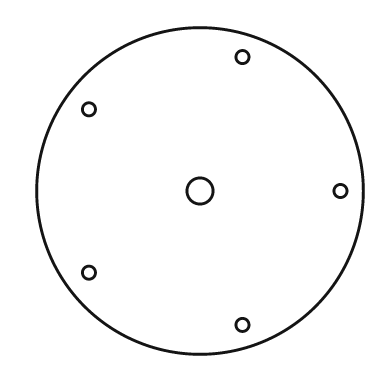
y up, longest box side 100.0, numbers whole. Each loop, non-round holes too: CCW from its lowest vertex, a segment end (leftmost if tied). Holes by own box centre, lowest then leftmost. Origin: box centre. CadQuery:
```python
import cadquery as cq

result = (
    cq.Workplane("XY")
    .moveTo(0.0, 0.0)
    .circle(50.0)
    .moveTo(13.0, -41.0)
    .circle(2.0)
    .moveTo(-34.0, -25.0)
    .circle(2.0)
    .moveTo(0.0, 0.0)
    .circle(4.0)
    .moveTo(43.0, 0.0)
    .circle(2.0)
    .moveTo(-34.0, 25.0)
    .circle(2.0)
    .moveTo(13.0, 41.0)
    .circle(2.0)
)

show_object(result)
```